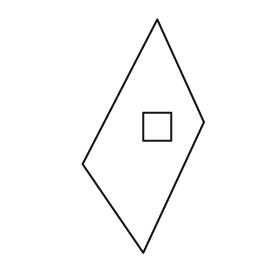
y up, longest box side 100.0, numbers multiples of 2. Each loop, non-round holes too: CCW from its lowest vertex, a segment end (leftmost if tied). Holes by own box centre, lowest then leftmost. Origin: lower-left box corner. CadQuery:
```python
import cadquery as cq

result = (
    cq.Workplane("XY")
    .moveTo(26.0, 0.0)
    .lineTo(52.0, 56.0)
    .lineTo(32.0, 100.0)
    .lineTo(0.0, 38.0)
    .close()
    .moveTo(26.0, 48.0)
    .lineTo(38.0, 48.0)
    .lineTo(38.0, 60.0)
    .lineTo(26.0, 60.0)
    .close()
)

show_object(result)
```